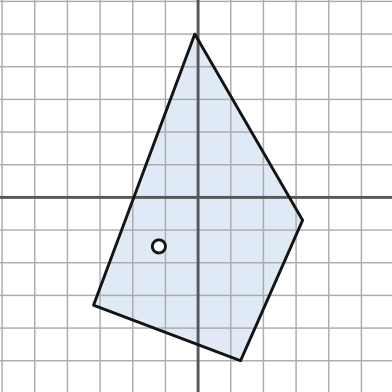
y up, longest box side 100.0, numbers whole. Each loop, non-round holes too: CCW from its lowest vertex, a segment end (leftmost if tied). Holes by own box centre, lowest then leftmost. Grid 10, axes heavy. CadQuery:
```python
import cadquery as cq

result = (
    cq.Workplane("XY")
    .moveTo(13.0, -50.0)
    .lineTo(32.0, -7.0)
    .lineTo(-1.0, 50.0)
    .lineTo(-32.0, -33.0)
    .close()
    .moveTo(-12.0, -15.0)
    .circle(2.0)
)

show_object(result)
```